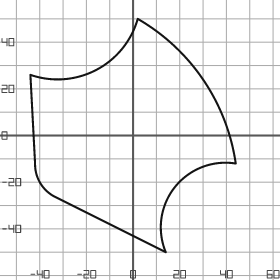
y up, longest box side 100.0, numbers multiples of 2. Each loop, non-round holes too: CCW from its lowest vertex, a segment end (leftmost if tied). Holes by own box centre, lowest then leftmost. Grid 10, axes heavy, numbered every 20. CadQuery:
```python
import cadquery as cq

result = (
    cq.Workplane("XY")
    .moveTo(14.0, -50.0)
    .threePointArc((18.0, -22.0), (44.0, -12.0))
    .threePointArc((30.0, 24.0), (2.0, 50.0))
    .threePointArc((-16.0, 28.0), (-44.0, 26.0))
    .lineTo(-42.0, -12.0)
    .threePointArc((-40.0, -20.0), (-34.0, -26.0))
    .close()
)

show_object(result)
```